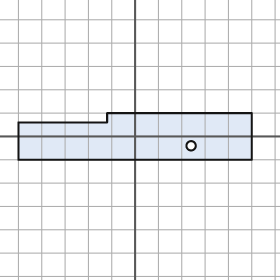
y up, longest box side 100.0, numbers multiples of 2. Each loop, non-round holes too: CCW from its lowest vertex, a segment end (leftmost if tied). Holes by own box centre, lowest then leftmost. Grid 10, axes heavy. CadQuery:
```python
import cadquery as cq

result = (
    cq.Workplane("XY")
    .moveTo(-50.0, -10.0)
    .lineTo(50.0, -10.0)
    .lineTo(50.0, 10.0)
    .lineTo(-12.0, 10.0)
    .lineTo(-12.0, 6.0)
    .lineTo(-50.0, 6.0)
    .close()
    .moveTo(24.0, -4.0)
    .circle(2.0)
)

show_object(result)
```